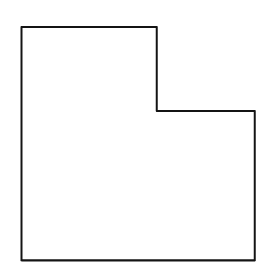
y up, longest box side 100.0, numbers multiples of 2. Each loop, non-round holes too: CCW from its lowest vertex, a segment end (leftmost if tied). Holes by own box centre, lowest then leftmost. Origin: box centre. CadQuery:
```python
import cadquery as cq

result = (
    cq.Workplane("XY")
    .moveTo(-50.0, -50.0)
    .lineTo(50.0, -50.0)
    .lineTo(50.0, 14.0)
    .lineTo(8.0, 14.0)
    .lineTo(8.0, 50.0)
    .lineTo(-50.0, 50.0)
    .close()
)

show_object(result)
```